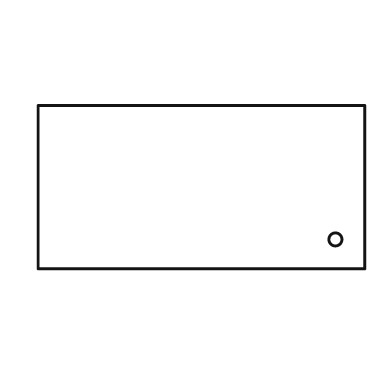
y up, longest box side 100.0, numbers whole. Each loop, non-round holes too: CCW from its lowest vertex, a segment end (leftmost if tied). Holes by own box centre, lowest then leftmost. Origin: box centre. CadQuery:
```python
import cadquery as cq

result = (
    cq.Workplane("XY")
    .moveTo(-50.0, -25.0)
    .lineTo(50.0, -25.0)
    .lineTo(50.0, 25.0)
    .lineTo(-50.0, 25.0)
    .close()
    .moveTo(41.0, -16.0)
    .circle(2.0)
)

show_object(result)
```